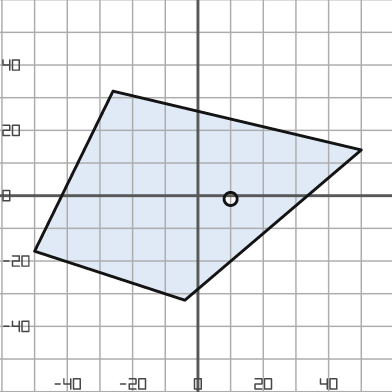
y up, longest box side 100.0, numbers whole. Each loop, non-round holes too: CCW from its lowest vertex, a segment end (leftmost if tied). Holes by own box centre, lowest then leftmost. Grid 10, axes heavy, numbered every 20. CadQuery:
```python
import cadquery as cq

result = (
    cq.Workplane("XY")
    .moveTo(-4.0, -32.0)
    .lineTo(50.0, 14.0)
    .lineTo(-26.0, 32.0)
    .lineTo(-50.0, -17.0)
    .close()
    .moveTo(10.0, -1.0)
    .circle(2.0)
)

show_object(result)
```